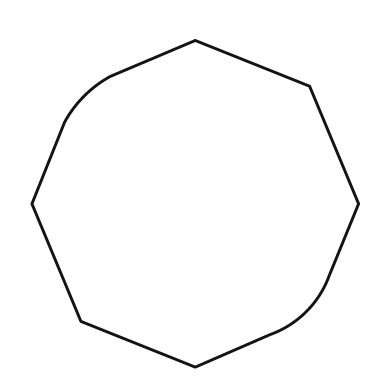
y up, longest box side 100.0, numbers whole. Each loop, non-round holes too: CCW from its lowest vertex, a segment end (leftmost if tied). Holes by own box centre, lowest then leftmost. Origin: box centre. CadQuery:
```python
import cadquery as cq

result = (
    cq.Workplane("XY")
    .moveTo(0.0, -50.0)
    .lineTo(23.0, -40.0)
    .threePointArc((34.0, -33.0), (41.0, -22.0))
    .lineTo(50.0, 0.0)
    .lineTo(35.0, 36.0)
    .lineTo(0.0, 50.0)
    .lineTo(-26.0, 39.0)
    .threePointArc((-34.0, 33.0), (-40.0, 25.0))
    .lineTo(-50.0, 0.0)
    .lineTo(-35.0, -36.0)
    .close()
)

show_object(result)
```